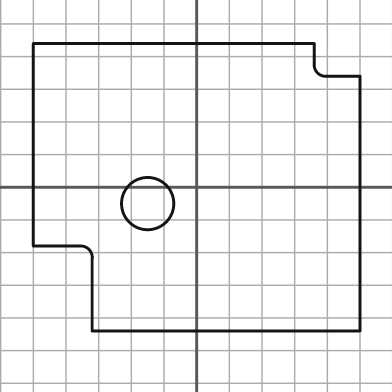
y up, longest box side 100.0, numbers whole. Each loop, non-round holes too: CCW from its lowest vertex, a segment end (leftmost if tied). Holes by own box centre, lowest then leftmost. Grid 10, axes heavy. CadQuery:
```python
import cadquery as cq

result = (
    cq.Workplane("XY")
    .moveTo(-32.0, -44.0)
    .lineTo(50.0, -44.0)
    .lineTo(50.0, 34.0)
    .lineTo(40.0, 34.0)
    .threePointArc((37.0, 35.0), (36.0, 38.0))
    .lineTo(36.0, 44.0)
    .lineTo(-50.0, 44.0)
    .lineTo(-50.0, -18.0)
    .lineTo(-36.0, -18.0)
    .threePointArc((-33.0, -19.0), (-32.0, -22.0))
    .close()
    .moveTo(-15.0, -5.0)
    .circle(8.0)
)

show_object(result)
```